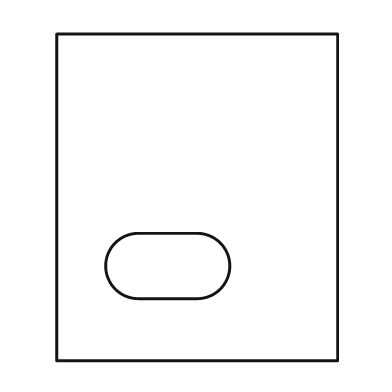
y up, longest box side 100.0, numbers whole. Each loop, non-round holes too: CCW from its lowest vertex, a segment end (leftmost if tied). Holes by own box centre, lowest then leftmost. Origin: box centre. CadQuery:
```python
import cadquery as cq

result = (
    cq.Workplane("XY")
    .moveTo(-43.0, -50.0)
    .lineTo(43.0, -50.0)
    .lineTo(43.0, 50.0)
    .lineTo(-43.0, 50.0)
    .close()
    .moveTo(-18.0, -31.0)
    .lineTo(0.0, -31.0)
    .threePointArc((10.0, -21.0), (0.0, -11.0))
    .lineTo(-18.0, -11.0)
    .threePointArc((-28.0, -21.0), (-18.0, -31.0))
    .close()
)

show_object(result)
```